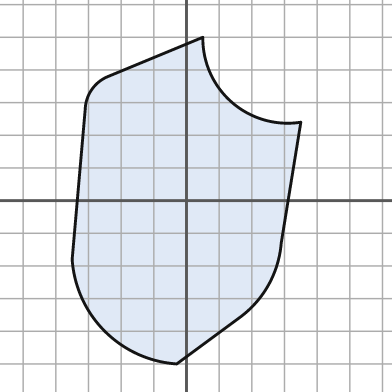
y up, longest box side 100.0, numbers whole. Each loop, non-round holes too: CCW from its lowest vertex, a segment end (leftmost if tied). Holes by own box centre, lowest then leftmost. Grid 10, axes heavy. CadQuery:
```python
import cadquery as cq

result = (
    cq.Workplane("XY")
    .moveTo(-3.0, -50.0)
    .lineTo(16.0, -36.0)
    .threePointArc((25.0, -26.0), (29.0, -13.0))
    .lineTo(35.0, 24.0)
    .threePointArc((14.0, 30.0), (5.0, 50.0))
    .lineTo(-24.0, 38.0)
    .threePointArc((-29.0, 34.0), (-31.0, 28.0))
    .lineTo(-35.0, -18.0)
    .threePointArc((-25.0, -40.0), (-3.0, -50.0))
    .close()
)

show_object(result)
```